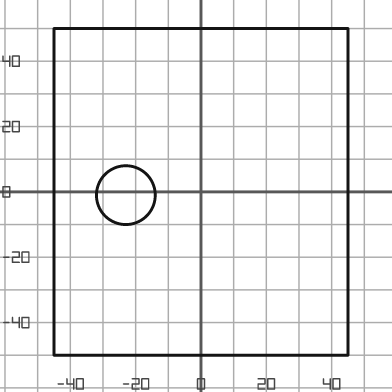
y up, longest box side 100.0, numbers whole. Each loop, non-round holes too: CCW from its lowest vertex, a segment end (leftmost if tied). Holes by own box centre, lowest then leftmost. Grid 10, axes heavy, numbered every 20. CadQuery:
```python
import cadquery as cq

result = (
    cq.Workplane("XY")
    .moveTo(-45.0, -50.0)
    .lineTo(45.0, -50.0)
    .lineTo(45.0, 50.0)
    .lineTo(-45.0, 50.0)
    .close()
    .moveTo(-23.0, -1.0)
    .circle(9.0)
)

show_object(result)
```